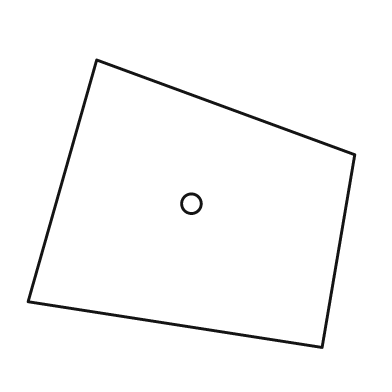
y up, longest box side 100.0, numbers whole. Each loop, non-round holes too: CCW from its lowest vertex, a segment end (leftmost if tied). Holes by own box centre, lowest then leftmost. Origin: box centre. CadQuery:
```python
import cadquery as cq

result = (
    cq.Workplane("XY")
    .moveTo(40.0, -44.0)
    .lineTo(50.0, 15.0)
    .lineTo(-29.0, 44.0)
    .lineTo(-50.0, -30.0)
    .close()
    .moveTo(0.0, 0.0)
    .circle(3.0)
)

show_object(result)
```